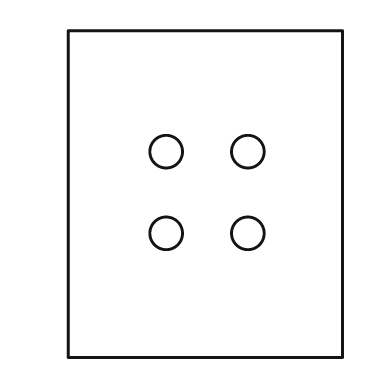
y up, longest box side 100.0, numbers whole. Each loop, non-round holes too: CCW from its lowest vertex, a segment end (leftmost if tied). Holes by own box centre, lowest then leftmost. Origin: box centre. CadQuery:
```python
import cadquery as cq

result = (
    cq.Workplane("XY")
    .moveTo(-42.0, -50.0)
    .lineTo(42.0, -50.0)
    .lineTo(42.0, 50.0)
    .lineTo(-42.0, 50.0)
    .close()
    .moveTo(-12.0, -12.0)
    .circle(5.0)
    .moveTo(13.0, -12.0)
    .circle(5.0)
    .moveTo(-12.0, 13.0)
    .circle(5.0)
    .moveTo(13.0, 13.0)
    .circle(5.0)
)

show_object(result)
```